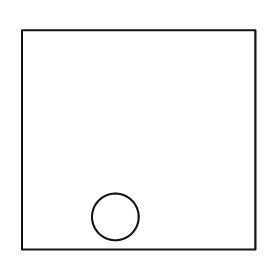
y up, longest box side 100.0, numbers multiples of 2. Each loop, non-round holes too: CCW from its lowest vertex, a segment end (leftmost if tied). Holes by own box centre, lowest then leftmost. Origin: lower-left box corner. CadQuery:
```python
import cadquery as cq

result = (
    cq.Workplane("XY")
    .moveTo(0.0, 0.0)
    .lineTo(100.0, 0.0)
    .lineTo(100.0, 94.0)
    .lineTo(0.0, 94.0)
    .close()
    .moveTo(40.0, 14.0)
    .circle(10.0)
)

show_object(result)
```